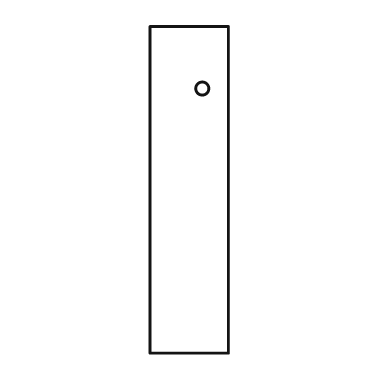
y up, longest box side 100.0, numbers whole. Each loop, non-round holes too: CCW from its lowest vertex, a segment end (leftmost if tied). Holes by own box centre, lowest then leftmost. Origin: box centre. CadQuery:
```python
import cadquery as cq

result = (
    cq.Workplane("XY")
    .moveTo(-12.0, -50.0)
    .lineTo(12.0, -50.0)
    .lineTo(12.0, 50.0)
    .lineTo(-12.0, 50.0)
    .close()
    .moveTo(4.0, 31.0)
    .circle(2.0)
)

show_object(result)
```